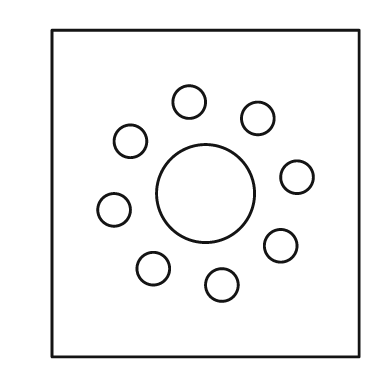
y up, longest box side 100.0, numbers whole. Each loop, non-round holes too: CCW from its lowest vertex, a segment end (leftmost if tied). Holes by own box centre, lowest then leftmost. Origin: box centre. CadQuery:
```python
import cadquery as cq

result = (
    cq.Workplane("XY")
    .moveTo(-47.0, -50.0)
    .lineTo(47.0, -50.0)
    .lineTo(47.0, 50.0)
    .lineTo(-47.0, 50.0)
    .close()
    .moveTo(5.0, -28.0)
    .circle(5.0)
    .moveTo(-16.0, -23.0)
    .circle(5.0)
    .moveTo(23.0, -16.0)
    .circle(5.0)
    .moveTo(-28.0, -5.0)
    .circle(5.0)
    .moveTo(0.0, 0.0)
    .circle(15.0)
    .moveTo(28.0, 5.0)
    .circle(5.0)
    .moveTo(-23.0, 16.0)
    .circle(5.0)
    .moveTo(16.0, 23.0)
    .circle(5.0)
    .moveTo(-5.0, 28.0)
    .circle(5.0)
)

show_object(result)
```